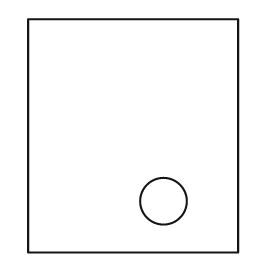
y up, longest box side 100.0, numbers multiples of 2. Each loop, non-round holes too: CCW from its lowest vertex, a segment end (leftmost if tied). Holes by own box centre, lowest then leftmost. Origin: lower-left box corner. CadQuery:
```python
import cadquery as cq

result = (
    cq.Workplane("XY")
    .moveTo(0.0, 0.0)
    .lineTo(90.0, 0.0)
    .lineTo(90.0, 100.0)
    .lineTo(0.0, 100.0)
    .close()
    .moveTo(58.0, 22.0)
    .circle(10.0)
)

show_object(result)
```